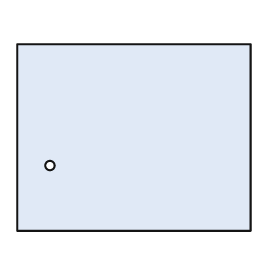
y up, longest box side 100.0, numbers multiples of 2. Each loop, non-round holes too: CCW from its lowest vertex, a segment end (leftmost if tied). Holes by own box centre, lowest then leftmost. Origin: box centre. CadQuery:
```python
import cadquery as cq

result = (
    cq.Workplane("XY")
    .moveTo(-50.0, -40.0)
    .lineTo(50.0, -40.0)
    .lineTo(50.0, 40.0)
    .lineTo(-50.0, 40.0)
    .close()
    .moveTo(-36.0, -12.0)
    .circle(2.0)
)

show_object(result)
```